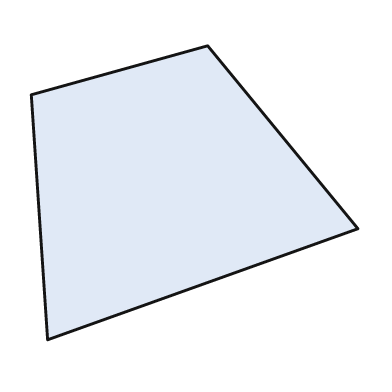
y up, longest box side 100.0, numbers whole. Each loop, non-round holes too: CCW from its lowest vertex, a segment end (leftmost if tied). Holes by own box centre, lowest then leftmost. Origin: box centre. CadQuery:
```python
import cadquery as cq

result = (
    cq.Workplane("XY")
    .moveTo(-45.0, -45.0)
    .lineTo(50.0, -11.0)
    .lineTo(4.0, 45.0)
    .lineTo(-50.0, 30.0)
    .close()
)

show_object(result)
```